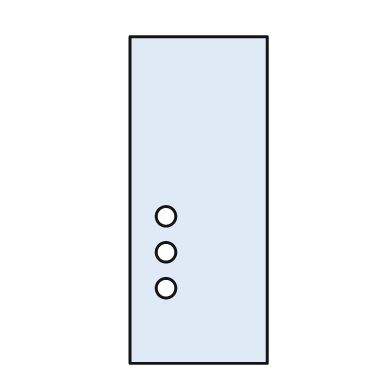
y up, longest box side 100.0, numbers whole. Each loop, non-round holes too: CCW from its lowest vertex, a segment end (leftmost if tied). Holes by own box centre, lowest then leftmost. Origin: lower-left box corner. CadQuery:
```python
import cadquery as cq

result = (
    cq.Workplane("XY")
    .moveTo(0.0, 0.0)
    .lineTo(42.0, 0.0)
    .lineTo(42.0, 100.0)
    .lineTo(0.0, 100.0)
    .close()
    .moveTo(11.0, 23.0)
    .circle(3.0)
    .moveTo(11.0, 34.0)
    .circle(3.0)
    .moveTo(11.0, 45.0)
    .circle(3.0)
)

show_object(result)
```